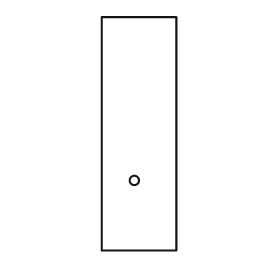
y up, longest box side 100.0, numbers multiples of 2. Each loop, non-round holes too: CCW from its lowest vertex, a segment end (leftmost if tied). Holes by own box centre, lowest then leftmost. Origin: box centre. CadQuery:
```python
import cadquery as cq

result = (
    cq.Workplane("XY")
    .moveTo(-16.0, -50.0)
    .lineTo(16.0, -50.0)
    .lineTo(16.0, 50.0)
    .lineTo(-16.0, 50.0)
    .close()
    .moveTo(-2.0, -20.0)
    .circle(2.0)
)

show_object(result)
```